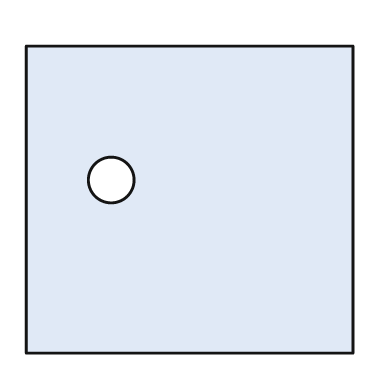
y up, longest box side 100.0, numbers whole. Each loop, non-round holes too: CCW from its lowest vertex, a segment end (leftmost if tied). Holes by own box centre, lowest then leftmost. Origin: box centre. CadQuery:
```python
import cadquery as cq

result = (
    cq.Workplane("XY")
    .moveTo(-50.0, -47.0)
    .lineTo(50.0, -47.0)
    .lineTo(50.0, 47.0)
    .lineTo(-50.0, 47.0)
    .close()
    .moveTo(-24.0, 6.0)
    .circle(7.0)
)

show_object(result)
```